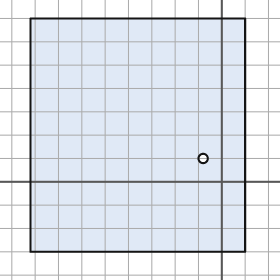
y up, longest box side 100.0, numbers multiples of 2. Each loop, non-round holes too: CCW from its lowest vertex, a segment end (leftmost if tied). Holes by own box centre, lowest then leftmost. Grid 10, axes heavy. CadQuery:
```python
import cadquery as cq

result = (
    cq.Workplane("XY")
    .moveTo(-82.0, -30.0)
    .lineTo(10.0, -30.0)
    .lineTo(10.0, 70.0)
    .lineTo(-82.0, 70.0)
    .close()
    .moveTo(-8.0, 10.0)
    .circle(2.0)
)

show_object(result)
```